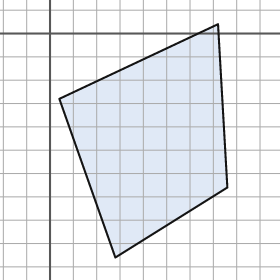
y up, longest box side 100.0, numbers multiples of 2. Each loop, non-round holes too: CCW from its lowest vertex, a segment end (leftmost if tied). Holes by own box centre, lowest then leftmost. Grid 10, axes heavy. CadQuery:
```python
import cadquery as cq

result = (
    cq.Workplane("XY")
    .moveTo(28.0, -96.0)
    .lineTo(76.0, -66.0)
    .lineTo(72.0, 4.0)
    .lineTo(4.0, -28.0)
    .close()
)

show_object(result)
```